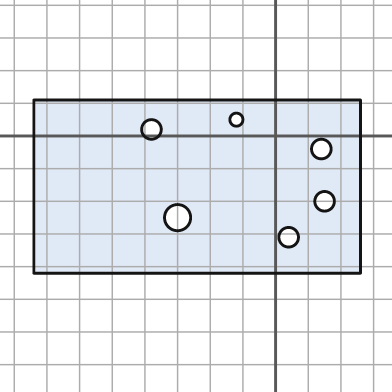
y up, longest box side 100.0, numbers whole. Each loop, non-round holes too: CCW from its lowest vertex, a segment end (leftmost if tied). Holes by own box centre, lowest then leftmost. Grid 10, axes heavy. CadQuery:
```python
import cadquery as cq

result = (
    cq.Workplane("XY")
    .moveTo(-74.0, -42.0)
    .lineTo(26.0, -42.0)
    .lineTo(26.0, 11.0)
    .lineTo(-74.0, 11.0)
    .close()
    .moveTo(4.0, -31.0)
    .circle(3.0)
    .moveTo(-30.0, -25.0)
    .circle(4.0)
    .moveTo(15.0, -20.0)
    .circle(3.0)
    .moveTo(14.0, -4.0)
    .circle(3.0)
    .moveTo(-38.0, 2.0)
    .circle(3.0)
    .moveTo(-12.0, 5.0)
    .circle(2.0)
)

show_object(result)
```